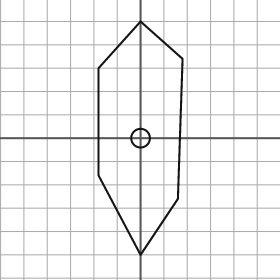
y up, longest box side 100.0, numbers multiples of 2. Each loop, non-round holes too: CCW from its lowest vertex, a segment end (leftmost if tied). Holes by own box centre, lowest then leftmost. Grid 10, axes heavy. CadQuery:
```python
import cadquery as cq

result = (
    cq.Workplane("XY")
    .moveTo(0.0, -50.0)
    .lineTo(16.0, -26.0)
    .lineTo(18.0, 34.0)
    .lineTo(0.0, 50.0)
    .lineTo(-18.0, 30.0)
    .lineTo(-18.0, -16.0)
    .close()
    .moveTo(0.0, 0.0)
    .circle(4.0)
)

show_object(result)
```